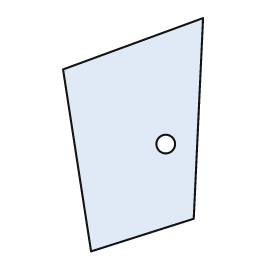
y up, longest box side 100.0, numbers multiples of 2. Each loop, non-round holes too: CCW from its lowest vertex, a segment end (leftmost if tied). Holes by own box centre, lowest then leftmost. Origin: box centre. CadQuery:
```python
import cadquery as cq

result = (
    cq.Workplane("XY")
    .moveTo(-18.0, -50.0)
    .lineTo(26.0, -36.0)
    .lineTo(30.0, 50.0)
    .lineTo(-30.0, 28.0)
    .close()
    .moveTo(14.0, -4.0)
    .circle(4.0)
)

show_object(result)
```